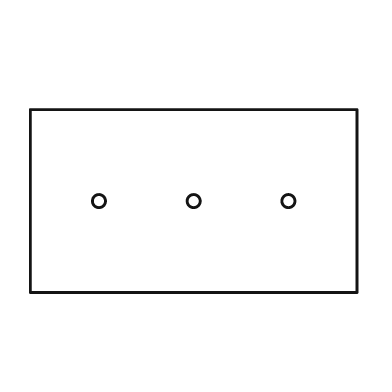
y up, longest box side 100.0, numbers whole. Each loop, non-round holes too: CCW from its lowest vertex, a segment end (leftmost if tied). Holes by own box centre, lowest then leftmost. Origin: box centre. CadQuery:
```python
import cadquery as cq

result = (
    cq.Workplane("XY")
    .moveTo(-50.0, -28.0)
    .lineTo(50.0, -28.0)
    .lineTo(50.0, 28.0)
    .lineTo(-50.0, 28.0)
    .close()
    .moveTo(-29.0, 0.0)
    .circle(2.0)
    .moveTo(0.0, 0.0)
    .circle(2.0)
    .moveTo(29.0, 0.0)
    .circle(2.0)
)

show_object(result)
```